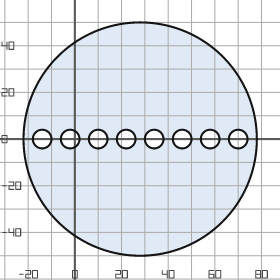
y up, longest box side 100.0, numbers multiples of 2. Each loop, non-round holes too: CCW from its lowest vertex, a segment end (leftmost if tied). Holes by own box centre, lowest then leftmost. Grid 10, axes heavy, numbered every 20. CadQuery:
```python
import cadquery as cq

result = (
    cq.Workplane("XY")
    .moveTo(28.0, 0.0)
    .circle(50.0)
    .moveTo(-14.0, 0.0)
    .circle(4.0)
    .moveTo(-2.0, 0.0)
    .circle(4.0)
    .moveTo(10.0, 0.0)
    .circle(4.0)
    .moveTo(22.0, 0.0)
    .circle(4.0)
    .moveTo(34.0, 0.0)
    .circle(4.0)
    .moveTo(46.0, 0.0)
    .circle(4.0)
    .moveTo(58.0, 0.0)
    .circle(4.0)
    .moveTo(70.0, 0.0)
    .circle(4.0)
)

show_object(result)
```